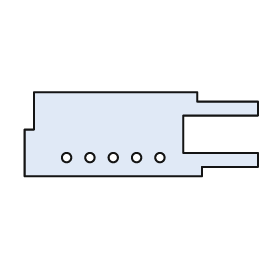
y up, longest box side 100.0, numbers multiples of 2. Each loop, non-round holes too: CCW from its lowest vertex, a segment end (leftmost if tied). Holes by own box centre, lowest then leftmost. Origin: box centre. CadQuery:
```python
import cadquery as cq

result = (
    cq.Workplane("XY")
    .moveTo(-50.0, -18.0)
    .lineTo(26.0, -18.0)
    .lineTo(26.0, -14.0)
    .lineTo(50.0, -14.0)
    .lineTo(50.0, -8.0)
    .lineTo(18.0, -8.0)
    .lineTo(18.0, 8.0)
    .lineTo(50.0, 8.0)
    .lineTo(50.0, 14.0)
    .lineTo(24.0, 14.0)
    .lineTo(24.0, 18.0)
    .lineTo(-46.0, 18.0)
    .lineTo(-46.0, 2.0)
    .lineTo(-50.0, 2.0)
    .close()
    .moveTo(-32.0, -10.0)
    .circle(2.0)
    .moveTo(-22.0, -10.0)
    .circle(2.0)
    .moveTo(-12.0, -10.0)
    .circle(2.0)
    .moveTo(-2.0, -10.0)
    .circle(2.0)
    .moveTo(8.0, -10.0)
    .circle(2.0)
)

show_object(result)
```